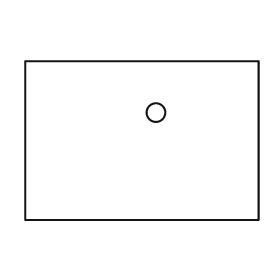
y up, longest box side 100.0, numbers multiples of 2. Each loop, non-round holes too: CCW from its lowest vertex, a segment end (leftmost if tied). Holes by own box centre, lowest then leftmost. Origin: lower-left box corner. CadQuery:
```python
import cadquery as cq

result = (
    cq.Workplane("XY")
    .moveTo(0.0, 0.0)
    .lineTo(100.0, 0.0)
    .lineTo(100.0, 68.0)
    .lineTo(0.0, 68.0)
    .close()
    .moveTo(56.0, 46.0)
    .circle(4.0)
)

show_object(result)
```